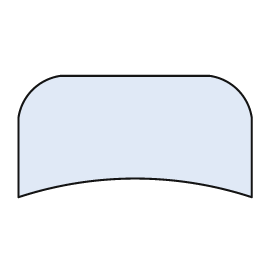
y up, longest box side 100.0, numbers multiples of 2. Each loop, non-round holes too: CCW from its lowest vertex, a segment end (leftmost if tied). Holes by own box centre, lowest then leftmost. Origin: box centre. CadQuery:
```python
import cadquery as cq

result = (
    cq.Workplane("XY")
    .moveTo(-50.0, -26.0)
    .threePointArc((0.0, -18.0), (50.0, -26.0))
    .lineTo(50.0, 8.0)
    .threePointArc((44.0, 20.0), (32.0, 26.0))
    .lineTo(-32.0, 26.0)
    .threePointArc((-44.0, 20.0), (-50.0, 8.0))
    .close()
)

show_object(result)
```